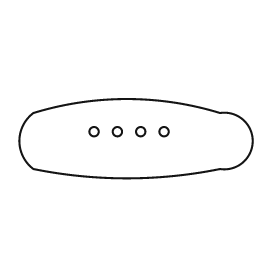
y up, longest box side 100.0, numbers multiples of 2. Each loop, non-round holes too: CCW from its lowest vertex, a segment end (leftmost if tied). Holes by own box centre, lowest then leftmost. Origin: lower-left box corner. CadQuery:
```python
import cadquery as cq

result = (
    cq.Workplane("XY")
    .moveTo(6.0, 4.0)
    .threePointArc((46.0, 0.0), (86.0, 4.0))
    .threePointArc((100.0, 16.0), (86.0, 28.0))
    .threePointArc((46.0, 34.0), (6.0, 28.0))
    .threePointArc((0.0, 16.0), (6.0, 4.0))
    .close()
    .moveTo(32.0, 20.0)
    .circle(2.0)
    .moveTo(42.0, 20.0)
    .circle(2.0)
    .moveTo(52.0, 20.0)
    .circle(2.0)
    .moveTo(62.0, 20.0)
    .circle(2.0)
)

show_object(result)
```